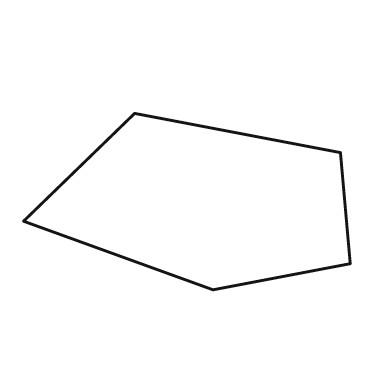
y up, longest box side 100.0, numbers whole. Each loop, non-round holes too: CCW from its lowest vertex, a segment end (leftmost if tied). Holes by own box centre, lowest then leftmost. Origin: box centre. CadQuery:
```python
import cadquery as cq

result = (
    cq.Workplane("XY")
    .moveTo(8.0, -27.0)
    .lineTo(50.0, -19.0)
    .lineTo(47.0, 15.0)
    .lineTo(-16.0, 27.0)
    .lineTo(-50.0, -6.0)
    .close()
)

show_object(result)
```